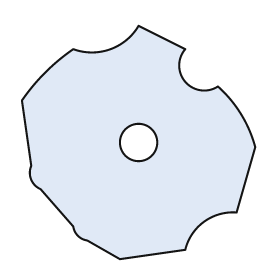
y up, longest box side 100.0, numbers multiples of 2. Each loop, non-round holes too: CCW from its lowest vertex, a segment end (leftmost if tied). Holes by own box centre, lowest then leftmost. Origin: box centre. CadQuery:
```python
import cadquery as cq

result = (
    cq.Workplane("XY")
    .moveTo(-8.0, -50.0)
    .lineTo(20.0, -46.0)
    .threePointArc((28.0, -34.0), (42.0, -30.0))
    .lineTo(50.0, -2.0)
    .threePointArc((44.0, 12.0), (34.0, 24.0))
    .threePointArc((20.0, 26.0), (20.0, 40.0))
    .lineTo(0.0, 50.0)
    .threePointArc((-12.0, 40.0), (-28.0, 40.0))
    .threePointArc((-40.0, 30.0), (-50.0, 18.0))
    .lineTo(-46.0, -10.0)
    .threePointArc((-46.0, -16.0), (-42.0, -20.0))
    .lineTo(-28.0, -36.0)
    .threePointArc((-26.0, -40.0), (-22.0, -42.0))
    .close()
    .moveTo(0.0, 0.0)
    .circle(8.0)
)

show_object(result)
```